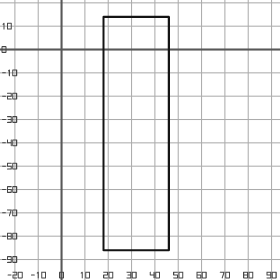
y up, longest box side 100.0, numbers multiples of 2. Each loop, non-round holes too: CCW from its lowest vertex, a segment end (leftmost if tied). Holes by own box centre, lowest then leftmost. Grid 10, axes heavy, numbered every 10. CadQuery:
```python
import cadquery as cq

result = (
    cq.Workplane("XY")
    .moveTo(18.0, -86.0)
    .lineTo(46.0, -86.0)
    .lineTo(46.0, 14.0)
    .lineTo(18.0, 14.0)
    .close()
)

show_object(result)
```